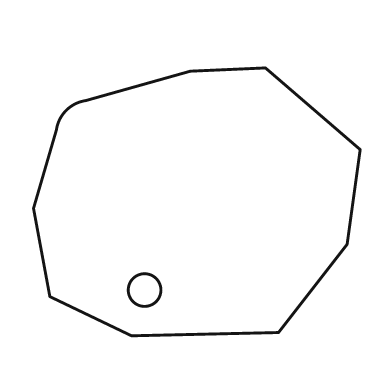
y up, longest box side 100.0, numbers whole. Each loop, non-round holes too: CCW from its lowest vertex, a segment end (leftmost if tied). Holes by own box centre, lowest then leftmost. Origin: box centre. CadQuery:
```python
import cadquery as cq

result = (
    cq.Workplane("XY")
    .moveTo(-20.0, -41.0)
    .lineTo(25.0, -40.0)
    .lineTo(46.0, -13.0)
    .lineTo(50.0, 16.0)
    .lineTo(21.0, 41.0)
    .lineTo(-2.0, 40.0)
    .lineTo(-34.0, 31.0)
    .threePointArc((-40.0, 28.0), (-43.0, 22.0))
    .lineTo(-50.0, -2.0)
    .lineTo(-45.0, -29.0)
    .close()
    .moveTo(-16.0, -27.0)
    .circle(5.0)
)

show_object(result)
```